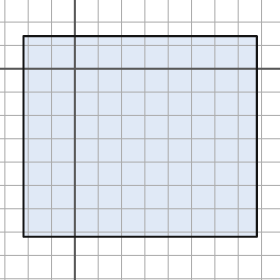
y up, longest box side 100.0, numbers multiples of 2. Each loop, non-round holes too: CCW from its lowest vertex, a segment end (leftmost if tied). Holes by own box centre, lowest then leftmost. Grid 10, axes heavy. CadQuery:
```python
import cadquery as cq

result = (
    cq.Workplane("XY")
    .moveTo(-22.0, -72.0)
    .lineTo(78.0, -72.0)
    .lineTo(78.0, 14.0)
    .lineTo(-22.0, 14.0)
    .close()
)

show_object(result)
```